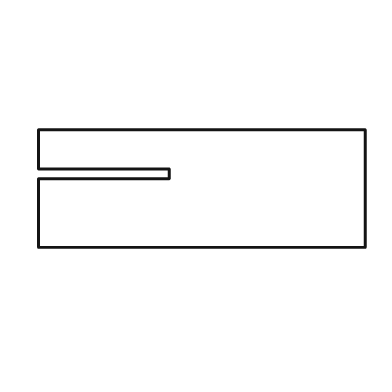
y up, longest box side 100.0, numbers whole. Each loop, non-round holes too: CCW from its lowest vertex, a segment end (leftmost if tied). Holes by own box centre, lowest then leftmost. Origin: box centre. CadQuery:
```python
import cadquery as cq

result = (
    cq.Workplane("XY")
    .moveTo(-50.0, -18.0)
    .lineTo(50.0, -18.0)
    .lineTo(50.0, 18.0)
    .lineTo(-50.0, 18.0)
    .lineTo(-50.0, 6.0)
    .lineTo(-10.0, 6.0)
    .lineTo(-10.0, 3.0)
    .lineTo(-50.0, 3.0)
    .close()
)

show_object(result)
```